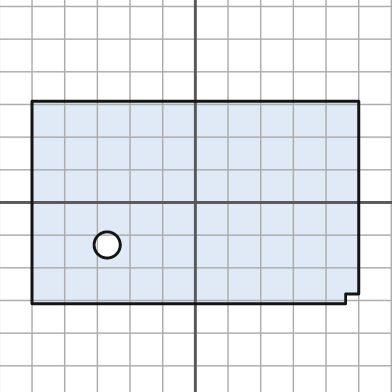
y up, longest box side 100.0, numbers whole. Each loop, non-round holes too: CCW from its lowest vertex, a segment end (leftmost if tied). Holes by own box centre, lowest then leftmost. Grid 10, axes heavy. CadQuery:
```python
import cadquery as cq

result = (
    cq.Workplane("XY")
    .moveTo(-50.0, -31.0)
    .lineTo(46.0, -31.0)
    .lineTo(46.0, -28.0)
    .lineTo(50.0, -28.0)
    .lineTo(50.0, 31.0)
    .lineTo(-50.0, 31.0)
    .close()
    .moveTo(-27.0, -13.0)
    .circle(4.0)
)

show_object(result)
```